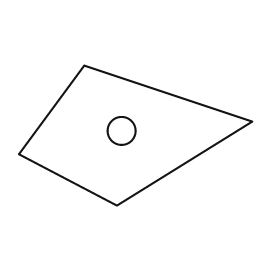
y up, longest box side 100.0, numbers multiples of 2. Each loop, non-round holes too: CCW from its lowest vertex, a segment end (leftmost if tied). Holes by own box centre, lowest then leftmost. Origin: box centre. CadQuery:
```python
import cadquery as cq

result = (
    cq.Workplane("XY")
    .moveTo(-8.0, -30.0)
    .lineTo(50.0, 6.0)
    .lineTo(-22.0, 30.0)
    .lineTo(-50.0, -8.0)
    .close()
    .moveTo(-6.0, 2.0)
    .circle(6.0)
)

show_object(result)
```